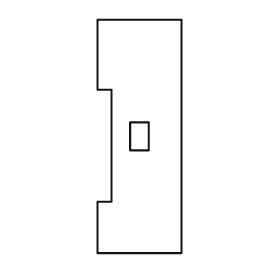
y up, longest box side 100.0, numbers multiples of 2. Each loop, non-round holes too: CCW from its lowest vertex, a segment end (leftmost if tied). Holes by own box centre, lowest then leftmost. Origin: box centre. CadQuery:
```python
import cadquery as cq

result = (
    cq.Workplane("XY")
    .moveTo(-18.0, -50.0)
    .lineTo(18.0, -50.0)
    .lineTo(18.0, 50.0)
    .lineTo(-18.0, 50.0)
    .lineTo(-18.0, 20.0)
    .lineTo(-12.0, 20.0)
    .lineTo(-12.0, -28.0)
    .lineTo(-18.0, -28.0)
    .close()
    .moveTo(-4.0, -6.0)
    .lineTo(4.0, -6.0)
    .lineTo(4.0, 6.0)
    .lineTo(-4.0, 6.0)
    .close()
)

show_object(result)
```